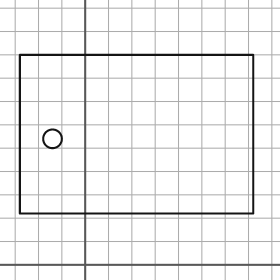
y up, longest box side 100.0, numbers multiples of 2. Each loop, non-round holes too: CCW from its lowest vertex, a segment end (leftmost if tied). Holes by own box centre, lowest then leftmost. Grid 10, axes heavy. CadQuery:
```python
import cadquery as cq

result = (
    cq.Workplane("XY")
    .moveTo(-28.0, 22.0)
    .lineTo(72.0, 22.0)
    .lineTo(72.0, 90.0)
    .lineTo(-28.0, 90.0)
    .close()
    .moveTo(-14.0, 54.0)
    .circle(4.0)
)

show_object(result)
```